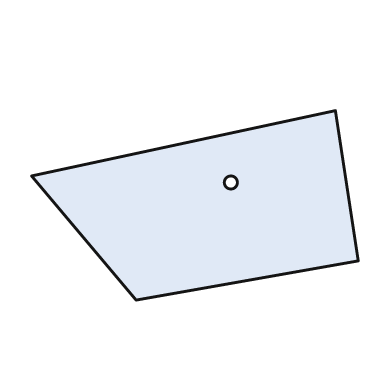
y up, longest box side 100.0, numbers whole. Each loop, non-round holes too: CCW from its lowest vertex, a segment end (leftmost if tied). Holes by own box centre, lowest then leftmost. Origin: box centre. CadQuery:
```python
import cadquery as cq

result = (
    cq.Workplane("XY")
    .moveTo(-18.0, -29.0)
    .lineTo(50.0, -17.0)
    .lineTo(43.0, 29.0)
    .lineTo(-50.0, 9.0)
    .close()
    .moveTo(11.0, 7.0)
    .circle(2.0)
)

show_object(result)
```